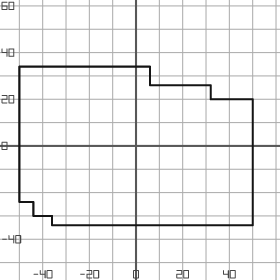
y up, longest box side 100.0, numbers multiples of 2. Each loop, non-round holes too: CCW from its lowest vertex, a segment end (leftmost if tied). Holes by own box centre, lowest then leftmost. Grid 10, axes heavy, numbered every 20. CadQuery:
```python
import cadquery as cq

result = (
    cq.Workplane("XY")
    .moveTo(-36.0, -34.0)
    .lineTo(50.0, -34.0)
    .lineTo(50.0, 20.0)
    .lineTo(32.0, 20.0)
    .lineTo(32.0, 26.0)
    .lineTo(6.0, 26.0)
    .lineTo(6.0, 34.0)
    .lineTo(-50.0, 34.0)
    .lineTo(-50.0, -24.0)
    .lineTo(-44.0, -24.0)
    .lineTo(-44.0, -30.0)
    .lineTo(-36.0, -30.0)
    .close()
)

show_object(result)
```